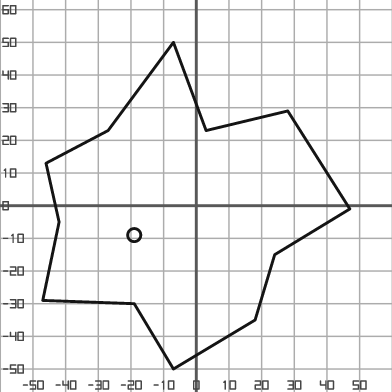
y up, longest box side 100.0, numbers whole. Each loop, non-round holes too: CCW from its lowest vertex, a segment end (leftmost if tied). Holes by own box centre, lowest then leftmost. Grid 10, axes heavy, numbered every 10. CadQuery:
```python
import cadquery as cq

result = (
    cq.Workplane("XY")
    .moveTo(-7.0, -50.0)
    .lineTo(18.0, -35.0)
    .lineTo(24.0, -15.0)
    .lineTo(47.0, -1.0)
    .lineTo(28.0, 29.0)
    .lineTo(3.0, 23.0)
    .lineTo(-7.0, 50.0)
    .lineTo(-27.0, 23.0)
    .lineTo(-46.0, 13.0)
    .lineTo(-42.0, -5.0)
    .lineTo(-47.0, -29.0)
    .lineTo(-19.0, -30.0)
    .close()
    .moveTo(-19.0, -9.0)
    .circle(2.0)
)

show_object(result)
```